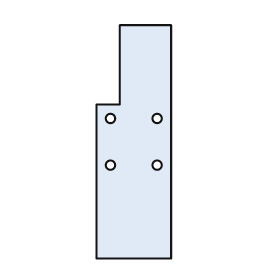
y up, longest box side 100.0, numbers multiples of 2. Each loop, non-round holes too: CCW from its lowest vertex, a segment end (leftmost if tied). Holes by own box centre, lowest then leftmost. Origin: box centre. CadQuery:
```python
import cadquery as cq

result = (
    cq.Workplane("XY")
    .moveTo(-16.0, -50.0)
    .lineTo(16.0, -50.0)
    .lineTo(16.0, 50.0)
    .lineTo(-6.0, 50.0)
    .lineTo(-6.0, 16.0)
    .lineTo(-16.0, 16.0)
    .close()
    .moveTo(-10.0, -10.0)
    .circle(2.0)
    .moveTo(10.0, -10.0)
    .circle(2.0)
    .moveTo(-10.0, 10.0)
    .circle(2.0)
    .moveTo(10.0, 10.0)
    .circle(2.0)
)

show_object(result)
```